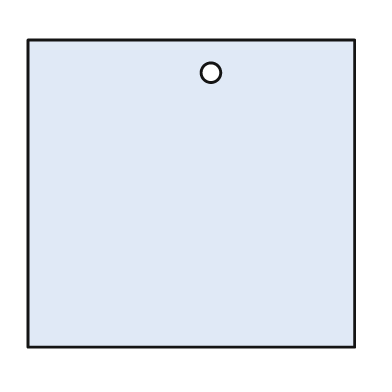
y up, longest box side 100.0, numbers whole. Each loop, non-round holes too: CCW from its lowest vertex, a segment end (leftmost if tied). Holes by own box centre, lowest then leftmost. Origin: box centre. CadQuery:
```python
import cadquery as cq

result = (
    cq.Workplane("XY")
    .moveTo(-50.0, -47.0)
    .lineTo(50.0, -47.0)
    .lineTo(50.0, 47.0)
    .lineTo(-50.0, 47.0)
    .close()
    .moveTo(6.0, 37.0)
    .circle(3.0)
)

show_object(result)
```